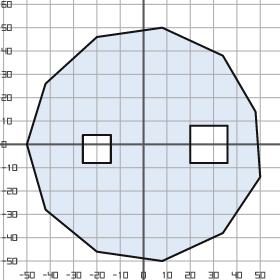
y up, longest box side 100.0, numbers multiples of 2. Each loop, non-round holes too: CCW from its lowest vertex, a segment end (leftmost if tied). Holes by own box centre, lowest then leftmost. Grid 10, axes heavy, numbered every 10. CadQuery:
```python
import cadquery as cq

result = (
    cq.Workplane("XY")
    .moveTo(8.0, -50.0)
    .lineTo(34.0, -38.0)
    .lineTo(50.0, -14.0)
    .lineTo(48.0, 14.0)
    .lineTo(34.0, 38.0)
    .lineTo(8.0, 50.0)
    .lineTo(-20.0, 46.0)
    .lineTo(-42.0, 26.0)
    .lineTo(-50.0, 0.0)
    .lineTo(-42.0, -28.0)
    .lineTo(-20.0, -46.0)
    .close()
    .moveTo(-26.0, -8.0)
    .lineTo(-14.0, -8.0)
    .lineTo(-14.0, 4.0)
    .lineTo(-26.0, 4.0)
    .close()
    .moveTo(20.0, -8.0)
    .lineTo(36.0, -8.0)
    .lineTo(36.0, 8.0)
    .lineTo(20.0, 8.0)
    .close()
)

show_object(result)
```